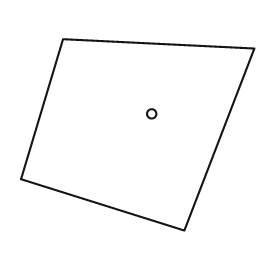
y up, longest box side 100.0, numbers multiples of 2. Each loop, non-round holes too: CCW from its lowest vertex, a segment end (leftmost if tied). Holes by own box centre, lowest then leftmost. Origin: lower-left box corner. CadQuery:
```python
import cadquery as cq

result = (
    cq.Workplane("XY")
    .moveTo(70.0, 0.0)
    .lineTo(100.0, 78.0)
    .lineTo(18.0, 82.0)
    .lineTo(0.0, 22.0)
    .close()
    .moveTo(56.0, 50.0)
    .circle(2.0)
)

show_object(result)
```